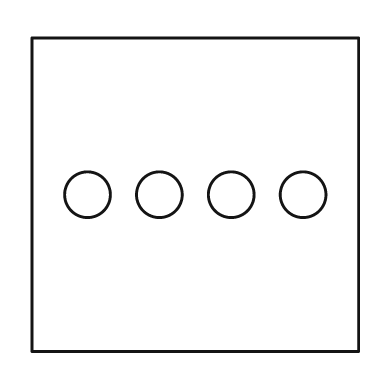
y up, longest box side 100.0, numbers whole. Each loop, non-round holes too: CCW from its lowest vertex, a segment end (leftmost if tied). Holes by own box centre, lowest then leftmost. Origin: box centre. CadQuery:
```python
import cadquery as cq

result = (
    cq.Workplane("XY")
    .moveTo(-50.0, -48.0)
    .lineTo(50.0, -48.0)
    .lineTo(50.0, 48.0)
    .lineTo(-50.0, 48.0)
    .close()
    .moveTo(-33.0, 0.0)
    .circle(7.0)
    .moveTo(-11.0, 0.0)
    .circle(7.0)
    .moveTo(11.0, 0.0)
    .circle(7.0)
    .moveTo(33.0, 0.0)
    .circle(7.0)
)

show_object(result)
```